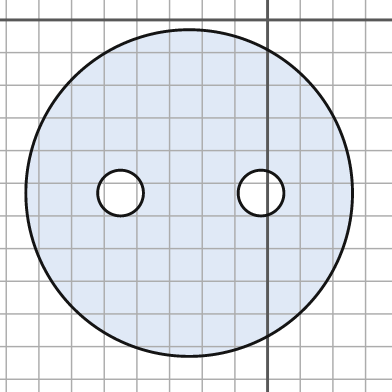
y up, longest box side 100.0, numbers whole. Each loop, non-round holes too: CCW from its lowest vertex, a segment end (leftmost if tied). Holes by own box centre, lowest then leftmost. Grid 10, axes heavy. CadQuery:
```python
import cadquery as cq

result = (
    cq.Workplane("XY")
    .moveTo(-24.0, -53.0)
    .circle(50.0)
    .moveTo(-45.0, -53.0)
    .circle(7.0)
    .moveTo(-2.0, -53.0)
    .circle(7.0)
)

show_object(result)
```